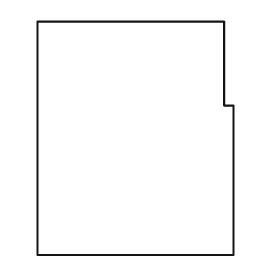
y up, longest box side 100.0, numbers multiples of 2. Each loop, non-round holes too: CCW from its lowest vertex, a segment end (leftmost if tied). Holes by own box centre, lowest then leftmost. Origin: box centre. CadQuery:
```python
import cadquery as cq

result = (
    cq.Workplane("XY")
    .moveTo(-42.0, -50.0)
    .lineTo(42.0, -50.0)
    .lineTo(42.0, 14.0)
    .lineTo(38.0, 14.0)
    .lineTo(38.0, 50.0)
    .lineTo(-42.0, 50.0)
    .close()
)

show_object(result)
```